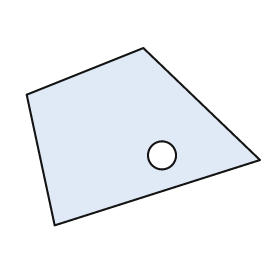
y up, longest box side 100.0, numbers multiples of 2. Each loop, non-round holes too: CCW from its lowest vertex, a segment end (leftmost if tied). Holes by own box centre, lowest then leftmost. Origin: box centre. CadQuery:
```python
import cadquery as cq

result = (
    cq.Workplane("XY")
    .moveTo(-38.0, -38.0)
    .lineTo(50.0, -10.0)
    .lineTo(0.0, 38.0)
    .lineTo(-50.0, 18.0)
    .close()
    .moveTo(8.0, -8.0)
    .circle(6.0)
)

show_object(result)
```